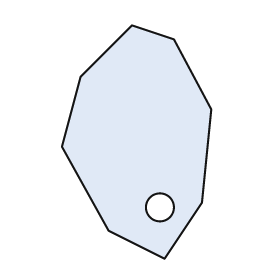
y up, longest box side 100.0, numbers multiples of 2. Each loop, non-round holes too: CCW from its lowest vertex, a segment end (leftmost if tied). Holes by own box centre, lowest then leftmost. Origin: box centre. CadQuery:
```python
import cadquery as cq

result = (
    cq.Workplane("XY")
    .moveTo(12.0, -50.0)
    .lineTo(28.0, -26.0)
    .lineTo(32.0, 14.0)
    .lineTo(16.0, 44.0)
    .lineTo(-2.0, 50.0)
    .lineTo(-24.0, 28.0)
    .lineTo(-32.0, -2.0)
    .lineTo(-12.0, -38.0)
    .close()
    .moveTo(10.0, -28.0)
    .circle(6.0)
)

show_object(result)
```